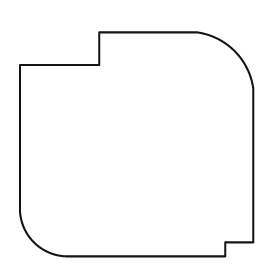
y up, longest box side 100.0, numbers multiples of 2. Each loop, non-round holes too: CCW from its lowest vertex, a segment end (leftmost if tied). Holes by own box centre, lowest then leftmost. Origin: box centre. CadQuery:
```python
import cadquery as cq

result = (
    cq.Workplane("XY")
    .moveTo(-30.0, -48.0)
    .lineTo(38.0, -48.0)
    .lineTo(38.0, -42.0)
    .lineTo(50.0, -42.0)
    .lineTo(50.0, 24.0)
    .threePointArc((42.0, 40.0), (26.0, 48.0))
    .lineTo(-16.0, 48.0)
    .lineTo(-16.0, 34.0)
    .lineTo(-50.0, 34.0)
    .lineTo(-50.0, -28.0)
    .threePointArc((-44.0, -42.0), (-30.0, -48.0))
    .close()
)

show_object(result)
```